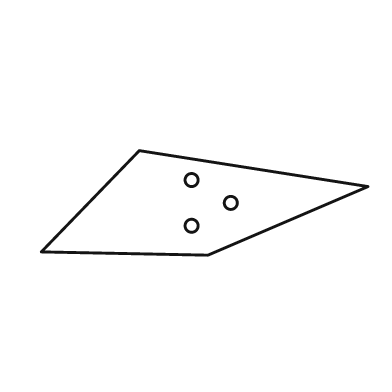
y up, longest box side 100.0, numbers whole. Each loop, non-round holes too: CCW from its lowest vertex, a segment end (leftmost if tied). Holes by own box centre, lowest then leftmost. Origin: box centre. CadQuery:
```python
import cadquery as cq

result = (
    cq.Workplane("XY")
    .moveTo(1.0, -16.0)
    .lineTo(50.0, 5.0)
    .lineTo(-20.0, 16.0)
    .lineTo(-50.0, -15.0)
    .close()
    .moveTo(-4.0, -7.0)
    .circle(2.0)
    .moveTo(8.0, 0.0)
    .circle(2.0)
    .moveTo(-4.0, 7.0)
    .circle(2.0)
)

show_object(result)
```